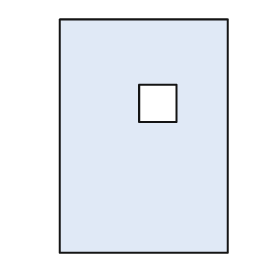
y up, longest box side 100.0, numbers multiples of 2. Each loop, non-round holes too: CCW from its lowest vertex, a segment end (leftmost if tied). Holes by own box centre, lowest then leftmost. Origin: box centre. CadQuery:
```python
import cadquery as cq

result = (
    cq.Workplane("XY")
    .moveTo(-36.0, -50.0)
    .lineTo(36.0, -50.0)
    .lineTo(36.0, 50.0)
    .lineTo(-36.0, 50.0)
    .close()
    .moveTo(-2.0, 6.0)
    .lineTo(14.0, 6.0)
    .lineTo(14.0, 22.0)
    .lineTo(-2.0, 22.0)
    .close()
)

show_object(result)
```